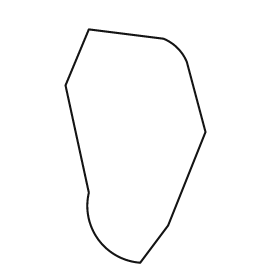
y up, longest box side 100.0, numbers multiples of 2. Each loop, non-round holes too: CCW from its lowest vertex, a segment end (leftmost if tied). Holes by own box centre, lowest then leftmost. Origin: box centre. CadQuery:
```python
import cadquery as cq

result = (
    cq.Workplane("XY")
    .moveTo(2.0, -50.0)
    .lineTo(14.0, -34.0)
    .lineTo(30.0, 6.0)
    .lineTo(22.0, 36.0)
    .threePointArc((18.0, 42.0), (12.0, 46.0))
    .lineTo(-20.0, 50.0)
    .lineTo(-30.0, 26.0)
    .lineTo(-20.0, -20.0)
    .threePointArc((-16.0, -40.0), (2.0, -50.0))
    .close()
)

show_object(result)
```